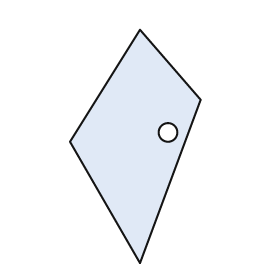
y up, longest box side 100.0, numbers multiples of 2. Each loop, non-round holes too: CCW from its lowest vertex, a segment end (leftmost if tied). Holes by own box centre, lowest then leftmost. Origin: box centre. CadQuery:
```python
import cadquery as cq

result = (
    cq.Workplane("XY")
    .moveTo(2.0, -50.0)
    .lineTo(28.0, 20.0)
    .lineTo(2.0, 50.0)
    .lineTo(-28.0, 2.0)
    .close()
    .moveTo(14.0, 6.0)
    .circle(4.0)
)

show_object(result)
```